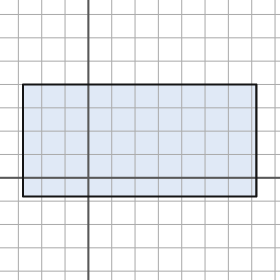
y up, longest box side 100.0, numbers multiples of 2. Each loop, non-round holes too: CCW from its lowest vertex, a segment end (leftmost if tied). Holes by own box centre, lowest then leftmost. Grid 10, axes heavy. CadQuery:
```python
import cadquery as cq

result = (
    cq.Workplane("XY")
    .moveTo(-28.0, -8.0)
    .lineTo(72.0, -8.0)
    .lineTo(72.0, 40.0)
    .lineTo(-28.0, 40.0)
    .close()
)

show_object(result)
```